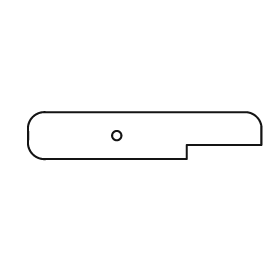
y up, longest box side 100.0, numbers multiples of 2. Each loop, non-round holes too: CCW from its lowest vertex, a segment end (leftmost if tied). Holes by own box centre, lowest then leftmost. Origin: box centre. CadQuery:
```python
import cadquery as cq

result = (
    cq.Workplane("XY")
    .moveTo(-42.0, -10.0)
    .lineTo(18.0, -10.0)
    .lineTo(18.0, -4.0)
    .lineTo(50.0, -4.0)
    .lineTo(50.0, 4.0)
    .threePointArc((48.0, 8.0), (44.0, 10.0))
    .lineTo(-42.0, 10.0)
    .threePointArc((-48.0, 8.0), (-50.0, 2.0))
    .lineTo(-50.0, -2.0)
    .threePointArc((-48.0, -8.0), (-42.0, -10.0))
    .close()
    .moveTo(-12.0, 0.0)
    .circle(2.0)
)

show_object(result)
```